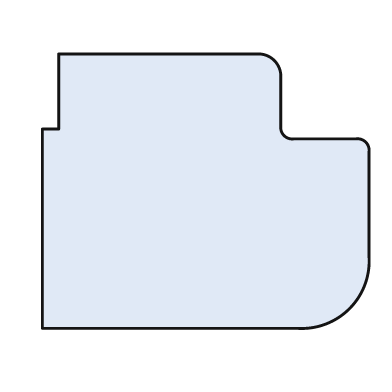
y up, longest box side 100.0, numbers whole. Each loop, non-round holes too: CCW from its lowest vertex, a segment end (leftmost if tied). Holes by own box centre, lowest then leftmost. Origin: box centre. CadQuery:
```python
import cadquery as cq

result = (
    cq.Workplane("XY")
    .moveTo(-50.0, -42.0)
    .lineTo(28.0, -42.0)
    .threePointArc((44.0, -36.0), (50.0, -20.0))
    .lineTo(50.0, 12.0)
    .threePointArc((49.0, 15.0), (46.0, 16.0))
    .lineTo(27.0, 16.0)
    .threePointArc((24.0, 17.0), (23.0, 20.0))
    .lineTo(23.0, 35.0)
    .threePointArc((21.0, 40.0), (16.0, 42.0))
    .lineTo(-45.0, 42.0)
    .lineTo(-45.0, 19.0)
    .lineTo(-50.0, 19.0)
    .close()
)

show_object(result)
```